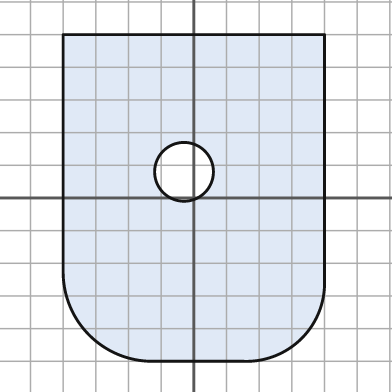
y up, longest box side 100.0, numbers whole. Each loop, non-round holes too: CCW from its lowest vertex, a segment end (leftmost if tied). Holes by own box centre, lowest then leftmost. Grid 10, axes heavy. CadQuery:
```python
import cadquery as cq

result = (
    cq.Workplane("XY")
    .moveTo(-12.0, -50.0)
    .lineTo(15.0, -50.0)
    .threePointArc((33.0, -43.0), (40.0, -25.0))
    .lineTo(40.0, 50.0)
    .lineTo(-40.0, 50.0)
    .lineTo(-40.0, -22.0)
    .threePointArc((-32.0, -42.0), (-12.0, -50.0))
    .close()
    .moveTo(-3.0, 8.0)
    .circle(9.0)
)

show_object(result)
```